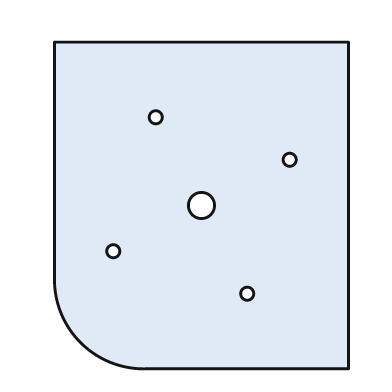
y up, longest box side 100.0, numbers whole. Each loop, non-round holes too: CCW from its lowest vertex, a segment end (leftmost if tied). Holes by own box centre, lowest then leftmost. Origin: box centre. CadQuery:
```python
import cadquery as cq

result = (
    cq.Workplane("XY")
    .moveTo(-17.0, -50.0)
    .lineTo(45.0, -50.0)
    .lineTo(45.0, 50.0)
    .lineTo(-45.0, 50.0)
    .lineTo(-45.0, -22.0)
    .threePointArc((-37.0, -42.0), (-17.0, -50.0))
    .close()
    .moveTo(14.0, -27.0)
    .circle(2.0)
    .moveTo(-27.0, -14.0)
    .circle(2.0)
    .moveTo(0.0, 0.0)
    .circle(4.0)
    .moveTo(27.0, 14.0)
    .circle(2.0)
    .moveTo(-14.0, 27.0)
    .circle(2.0)
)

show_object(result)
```